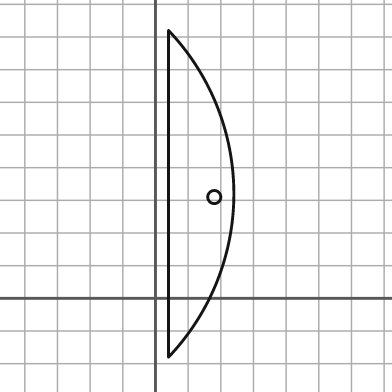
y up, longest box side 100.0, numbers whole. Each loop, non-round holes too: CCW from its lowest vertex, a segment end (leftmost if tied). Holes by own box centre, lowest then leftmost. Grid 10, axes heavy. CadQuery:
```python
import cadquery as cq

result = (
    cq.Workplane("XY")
    .moveTo(4.0, -18.0)
    .threePointArc((24.0, 32.0), (4.0, 82.0))
    .close()
    .moveTo(18.0, 31.0)
    .circle(2.0)
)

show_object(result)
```